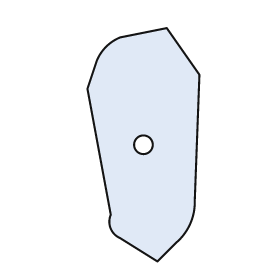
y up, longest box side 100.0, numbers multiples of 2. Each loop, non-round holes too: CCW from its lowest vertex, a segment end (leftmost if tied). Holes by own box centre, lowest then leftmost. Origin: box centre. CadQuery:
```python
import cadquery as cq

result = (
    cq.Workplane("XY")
    .moveTo(6.0, -50.0)
    .lineTo(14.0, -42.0)
    .threePointArc((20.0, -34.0), (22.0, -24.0))
    .lineTo(24.0, 30.0)
    .lineTo(10.0, 50.0)
    .lineTo(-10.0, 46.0)
    .threePointArc((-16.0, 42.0), (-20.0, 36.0))
    .lineTo(-24.0, 24.0)
    .lineTo(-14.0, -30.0)
    .threePointArc((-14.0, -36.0), (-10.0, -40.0))
    .close()
    .moveTo(0.0, 0.0)
    .circle(4.0)
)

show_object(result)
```